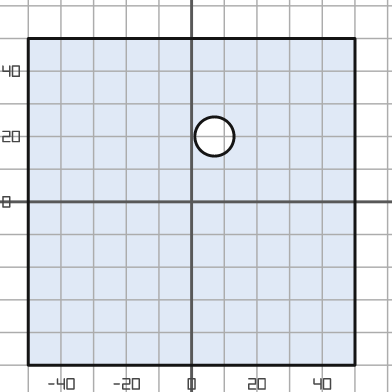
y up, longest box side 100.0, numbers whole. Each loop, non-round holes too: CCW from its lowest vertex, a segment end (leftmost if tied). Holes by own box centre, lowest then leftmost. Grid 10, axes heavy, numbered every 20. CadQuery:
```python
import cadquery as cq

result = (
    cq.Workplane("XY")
    .moveTo(-50.0, -50.0)
    .lineTo(50.0, -50.0)
    .lineTo(50.0, 50.0)
    .lineTo(-50.0, 50.0)
    .close()
    .moveTo(7.0, 20.0)
    .circle(6.0)
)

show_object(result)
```